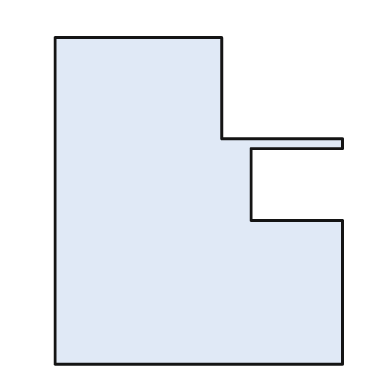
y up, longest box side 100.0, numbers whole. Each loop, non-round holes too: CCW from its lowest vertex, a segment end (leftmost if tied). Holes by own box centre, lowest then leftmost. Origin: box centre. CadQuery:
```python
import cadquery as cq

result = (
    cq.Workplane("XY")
    .moveTo(-44.0, -50.0)
    .lineTo(44.0, -50.0)
    .lineTo(44.0, -6.0)
    .lineTo(16.0, -6.0)
    .lineTo(16.0, 16.0)
    .lineTo(44.0, 16.0)
    .lineTo(44.0, 19.0)
    .lineTo(7.0, 19.0)
    .lineTo(7.0, 50.0)
    .lineTo(-44.0, 50.0)
    .close()
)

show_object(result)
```